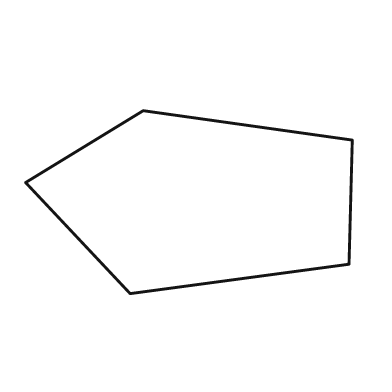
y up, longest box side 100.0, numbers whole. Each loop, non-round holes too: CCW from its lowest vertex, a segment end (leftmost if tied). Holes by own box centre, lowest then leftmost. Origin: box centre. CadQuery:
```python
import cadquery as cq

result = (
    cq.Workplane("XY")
    .moveTo(-18.0, -28.0)
    .lineTo(49.0, -19.0)
    .lineTo(50.0, 19.0)
    .lineTo(-14.0, 28.0)
    .lineTo(-50.0, 6.0)
    .close()
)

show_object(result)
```